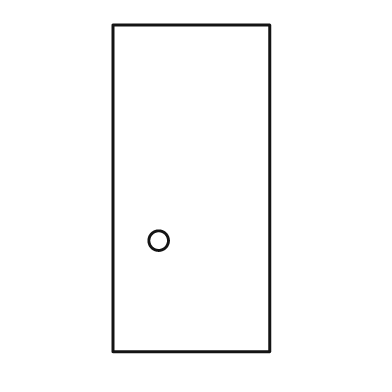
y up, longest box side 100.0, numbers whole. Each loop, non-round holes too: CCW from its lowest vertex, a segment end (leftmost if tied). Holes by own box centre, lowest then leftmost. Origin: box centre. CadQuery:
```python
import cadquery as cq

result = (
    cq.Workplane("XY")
    .moveTo(-24.0, -50.0)
    .lineTo(24.0, -50.0)
    .lineTo(24.0, 50.0)
    .lineTo(-24.0, 50.0)
    .close()
    .moveTo(-10.0, -16.0)
    .circle(3.0)
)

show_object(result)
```